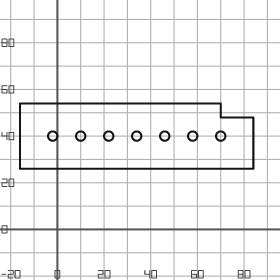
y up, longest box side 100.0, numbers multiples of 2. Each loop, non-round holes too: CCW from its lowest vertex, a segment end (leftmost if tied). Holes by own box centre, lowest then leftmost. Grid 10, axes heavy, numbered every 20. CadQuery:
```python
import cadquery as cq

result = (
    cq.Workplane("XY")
    .moveTo(-16.0, 26.0)
    .lineTo(84.0, 26.0)
    .lineTo(84.0, 48.0)
    .lineTo(70.0, 48.0)
    .lineTo(70.0, 54.0)
    .lineTo(-16.0, 54.0)
    .close()
    .moveTo(-2.0, 40.0)
    .circle(2.0)
    .moveTo(10.0, 40.0)
    .circle(2.0)
    .moveTo(22.0, 40.0)
    .circle(2.0)
    .moveTo(34.0, 40.0)
    .circle(2.0)
    .moveTo(46.0, 40.0)
    .circle(2.0)
    .moveTo(58.0, 40.0)
    .circle(2.0)
    .moveTo(70.0, 40.0)
    .circle(2.0)
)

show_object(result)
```